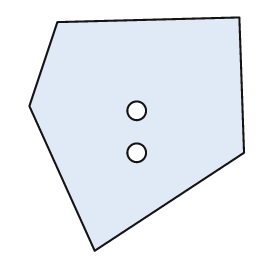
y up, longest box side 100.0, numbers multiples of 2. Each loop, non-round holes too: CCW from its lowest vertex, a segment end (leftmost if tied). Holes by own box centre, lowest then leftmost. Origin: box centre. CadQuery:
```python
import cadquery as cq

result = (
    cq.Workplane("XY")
    .moveTo(-18.0, -50.0)
    .lineTo(46.0, -8.0)
    .lineTo(44.0, 50.0)
    .lineTo(-34.0, 48.0)
    .lineTo(-46.0, 12.0)
    .close()
    .moveTo(0.0, -8.0)
    .circle(4.0)
    .moveTo(0.0, 10.0)
    .circle(4.0)
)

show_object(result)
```